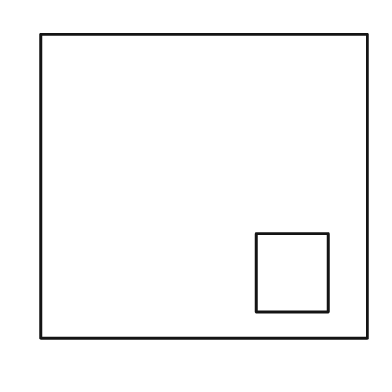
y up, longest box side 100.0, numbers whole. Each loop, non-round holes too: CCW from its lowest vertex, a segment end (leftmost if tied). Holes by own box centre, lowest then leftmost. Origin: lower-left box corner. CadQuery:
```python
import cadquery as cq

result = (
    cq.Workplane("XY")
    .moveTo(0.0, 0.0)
    .lineTo(100.0, 0.0)
    .lineTo(100.0, 93.0)
    .lineTo(0.0, 93.0)
    .close()
    .moveTo(66.0, 8.0)
    .lineTo(88.0, 8.0)
    .lineTo(88.0, 32.0)
    .lineTo(66.0, 32.0)
    .close()
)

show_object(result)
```